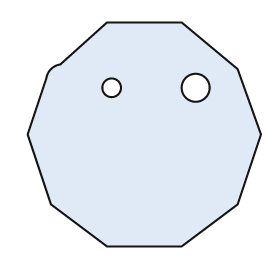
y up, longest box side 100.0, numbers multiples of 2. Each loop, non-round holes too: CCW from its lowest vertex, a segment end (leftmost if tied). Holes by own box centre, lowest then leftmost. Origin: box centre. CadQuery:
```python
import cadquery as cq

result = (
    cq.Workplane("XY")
    .moveTo(-16.0, -48.0)
    .lineTo(16.0, -48.0)
    .lineTo(40.0, -30.0)
    .lineTo(50.0, 0.0)
    .lineTo(40.0, 28.0)
    .lineTo(16.0, 48.0)
    .lineTo(-16.0, 48.0)
    .lineTo(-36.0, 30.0)
    .threePointArc((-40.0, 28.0), (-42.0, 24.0))
    .lineTo(-50.0, 0.0)
    .lineTo(-40.0, -30.0)
    .close()
    .moveTo(-14.0, 20.0)
    .circle(4.0)
    .moveTo(22.0, 20.0)
    .circle(6.0)
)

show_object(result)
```